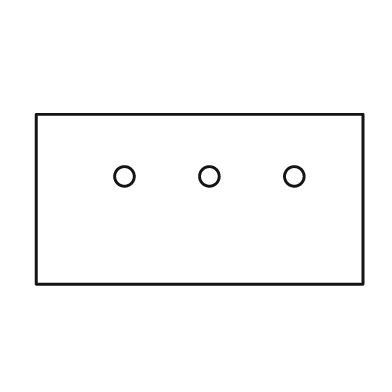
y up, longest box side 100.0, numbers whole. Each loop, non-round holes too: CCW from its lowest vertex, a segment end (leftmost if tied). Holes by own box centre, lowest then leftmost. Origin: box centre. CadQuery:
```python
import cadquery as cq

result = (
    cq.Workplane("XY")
    .moveTo(-50.0, -26.0)
    .lineTo(50.0, -26.0)
    .lineTo(50.0, 26.0)
    .lineTo(-50.0, 26.0)
    .close()
    .moveTo(-23.0, 7.0)
    .circle(3.0)
    .moveTo(3.0, 7.0)
    .circle(3.0)
    .moveTo(29.0, 7.0)
    .circle(3.0)
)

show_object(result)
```